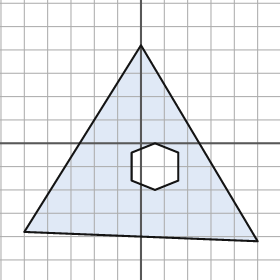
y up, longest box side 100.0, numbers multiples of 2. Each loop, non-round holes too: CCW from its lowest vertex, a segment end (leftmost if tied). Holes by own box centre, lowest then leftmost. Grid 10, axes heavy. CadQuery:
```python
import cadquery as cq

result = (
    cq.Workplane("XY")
    .moveTo(50.0, -42.0)
    .lineTo(0.0, 42.0)
    .lineTo(-50.0, -38.0)
    .close()
    .moveTo(6.0, -20.0)
    .lineTo(16.0, -16.0)
    .lineTo(16.0, -4.0)
    .lineTo(6.0, 0.0)
    .lineTo(-4.0, -4.0)
    .lineTo(-4.0, -16.0)
    .close()
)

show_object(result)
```